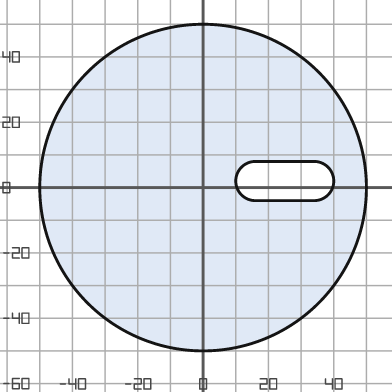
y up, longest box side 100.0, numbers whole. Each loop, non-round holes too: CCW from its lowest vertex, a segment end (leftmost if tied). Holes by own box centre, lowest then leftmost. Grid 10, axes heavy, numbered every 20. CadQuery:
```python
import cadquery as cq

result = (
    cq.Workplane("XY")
    .moveTo(0.0, 0.0)
    .circle(50.0)
    .moveTo(16.0, -4.0)
    .lineTo(34.0, -4.0)
    .threePointArc((40.0, 2.0), (34.0, 8.0))
    .lineTo(16.0, 8.0)
    .threePointArc((10.0, 2.0), (16.0, -4.0))
    .close()
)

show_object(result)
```